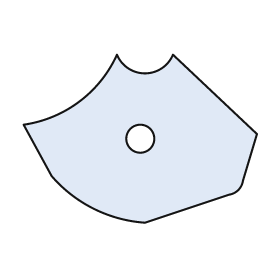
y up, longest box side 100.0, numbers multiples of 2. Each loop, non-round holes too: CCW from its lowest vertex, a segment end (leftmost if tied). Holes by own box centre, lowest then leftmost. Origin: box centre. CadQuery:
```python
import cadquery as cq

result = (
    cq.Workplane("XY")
    .moveTo(2.0, -36.0)
    .lineTo(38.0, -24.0)
    .threePointArc((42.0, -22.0), (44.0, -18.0))
    .lineTo(50.0, 2.0)
    .lineTo(14.0, 36.0)
    .threePointArc((2.0, 28.0), (-10.0, 36.0))
    .threePointArc((-26.0, 16.0), (-50.0, 6.0))
    .lineTo(-38.0, -16.0)
    .threePointArc((-20.0, -30.0), (2.0, -36.0))
    .close()
    .moveTo(0.0, 0.0)
    .circle(6.0)
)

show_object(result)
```